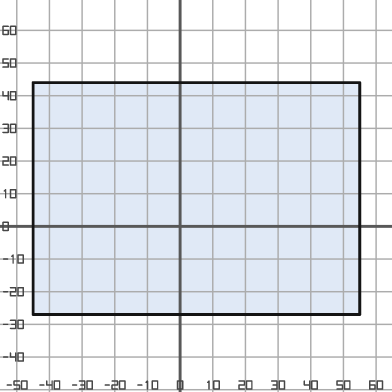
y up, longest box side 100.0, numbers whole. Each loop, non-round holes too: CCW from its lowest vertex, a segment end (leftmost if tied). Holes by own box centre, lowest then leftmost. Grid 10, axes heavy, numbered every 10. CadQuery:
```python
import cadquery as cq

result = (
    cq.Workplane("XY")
    .moveTo(-45.0, -27.0)
    .lineTo(55.0, -27.0)
    .lineTo(55.0, 44.0)
    .lineTo(-45.0, 44.0)
    .close()
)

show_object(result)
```